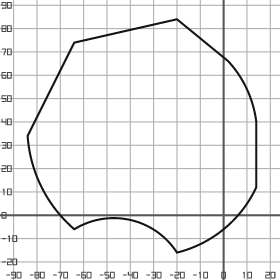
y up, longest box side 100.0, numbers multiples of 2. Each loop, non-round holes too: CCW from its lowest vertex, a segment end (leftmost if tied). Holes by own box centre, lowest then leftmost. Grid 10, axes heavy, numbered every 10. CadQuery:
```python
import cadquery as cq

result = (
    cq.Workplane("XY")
    .moveTo(-20.0, -16.0)
    .threePointArc((0.0, -6.0), (14.0, 12.0))
    .lineTo(14.0, 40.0)
    .threePointArc((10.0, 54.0), (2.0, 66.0))
    .lineTo(-20.0, 84.0)
    .lineTo(-64.0, 74.0)
    .lineTo(-84.0, 34.0)
    .threePointArc((-78.0, 12.0), (-64.0, -6.0))
    .threePointArc((-40.0, -2.0), (-20.0, -16.0))
    .close()
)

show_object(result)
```